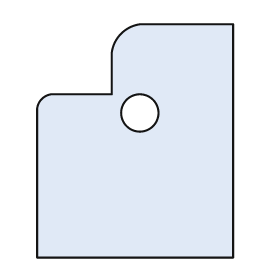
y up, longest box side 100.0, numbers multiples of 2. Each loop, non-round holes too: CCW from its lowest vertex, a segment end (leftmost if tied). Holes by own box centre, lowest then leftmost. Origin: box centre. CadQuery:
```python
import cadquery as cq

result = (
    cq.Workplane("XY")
    .moveTo(-42.0, -50.0)
    .lineTo(42.0, -50.0)
    .lineTo(42.0, 50.0)
    .lineTo(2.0, 50.0)
    .threePointArc((-6.0, 46.0), (-10.0, 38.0))
    .lineTo(-10.0, 20.0)
    .lineTo(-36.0, 20.0)
    .threePointArc((-40.0, 18.0), (-42.0, 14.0))
    .close()
    .moveTo(2.0, 12.0)
    .circle(8.0)
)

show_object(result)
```